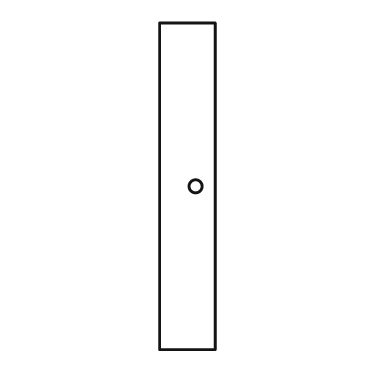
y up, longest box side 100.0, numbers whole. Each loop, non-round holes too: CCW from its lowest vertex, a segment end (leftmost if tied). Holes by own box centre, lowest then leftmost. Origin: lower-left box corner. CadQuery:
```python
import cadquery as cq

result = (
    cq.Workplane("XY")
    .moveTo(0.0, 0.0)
    .lineTo(17.0, 0.0)
    .lineTo(17.0, 100.0)
    .lineTo(0.0, 100.0)
    .close()
    .moveTo(11.0, 50.0)
    .circle(2.0)
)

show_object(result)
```